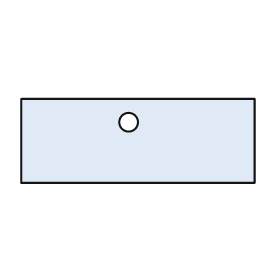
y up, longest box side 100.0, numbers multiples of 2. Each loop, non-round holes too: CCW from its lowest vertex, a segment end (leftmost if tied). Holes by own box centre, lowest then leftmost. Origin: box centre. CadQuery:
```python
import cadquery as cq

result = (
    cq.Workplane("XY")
    .moveTo(-50.0, -18.0)
    .lineTo(50.0, -18.0)
    .lineTo(50.0, 18.0)
    .lineTo(-50.0, 18.0)
    .close()
    .moveTo(-4.0, 8.0)
    .circle(4.0)
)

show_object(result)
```